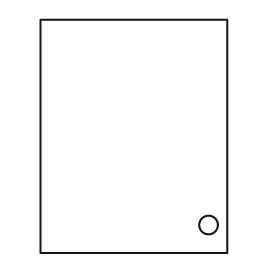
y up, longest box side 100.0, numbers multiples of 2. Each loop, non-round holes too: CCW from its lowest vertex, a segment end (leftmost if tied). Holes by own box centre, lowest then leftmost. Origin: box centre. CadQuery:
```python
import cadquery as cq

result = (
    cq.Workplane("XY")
    .moveTo(-40.0, -50.0)
    .lineTo(40.0, -50.0)
    .lineTo(40.0, 50.0)
    .lineTo(-40.0, 50.0)
    .close()
    .moveTo(32.0, -38.0)
    .circle(4.0)
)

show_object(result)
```